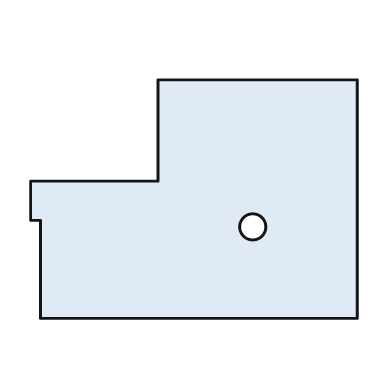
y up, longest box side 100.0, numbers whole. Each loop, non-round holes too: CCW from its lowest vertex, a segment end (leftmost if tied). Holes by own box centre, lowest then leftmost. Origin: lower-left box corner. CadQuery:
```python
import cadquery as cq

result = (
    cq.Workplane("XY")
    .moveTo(3.0, 0.0)
    .lineTo(100.0, 0.0)
    .lineTo(100.0, 73.0)
    .lineTo(39.0, 73.0)
    .lineTo(39.0, 42.0)
    .lineTo(0.0, 42.0)
    .lineTo(0.0, 30.0)
    .lineTo(3.0, 30.0)
    .close()
    .moveTo(68.0, 28.0)
    .circle(4.0)
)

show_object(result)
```